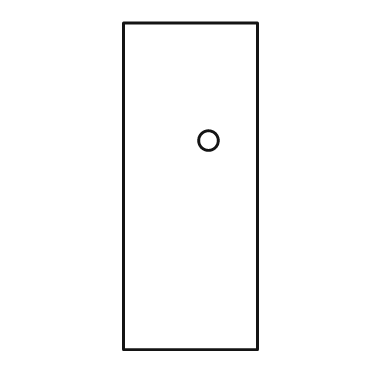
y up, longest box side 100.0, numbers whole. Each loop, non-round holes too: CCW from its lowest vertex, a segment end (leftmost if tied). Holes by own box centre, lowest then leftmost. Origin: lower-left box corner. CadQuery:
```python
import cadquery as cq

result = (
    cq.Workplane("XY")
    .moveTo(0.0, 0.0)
    .lineTo(41.0, 0.0)
    .lineTo(41.0, 100.0)
    .lineTo(0.0, 100.0)
    .close()
    .moveTo(26.0, 64.0)
    .circle(3.0)
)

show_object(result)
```